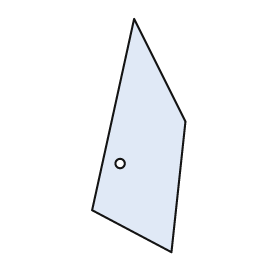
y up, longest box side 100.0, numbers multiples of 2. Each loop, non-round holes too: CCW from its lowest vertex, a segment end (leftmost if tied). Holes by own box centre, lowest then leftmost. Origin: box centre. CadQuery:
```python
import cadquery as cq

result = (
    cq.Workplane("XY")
    .moveTo(14.0, -50.0)
    .lineTo(20.0, 6.0)
    .lineTo(-2.0, 50.0)
    .lineTo(-20.0, -32.0)
    .close()
    .moveTo(-8.0, -12.0)
    .circle(2.0)
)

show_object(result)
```